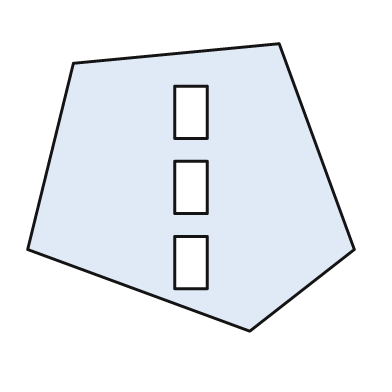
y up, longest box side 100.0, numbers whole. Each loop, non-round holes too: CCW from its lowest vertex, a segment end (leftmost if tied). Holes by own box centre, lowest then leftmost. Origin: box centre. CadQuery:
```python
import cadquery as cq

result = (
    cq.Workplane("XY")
    .moveTo(18.0, -44.0)
    .lineTo(50.0, -19.0)
    .lineTo(27.0, 44.0)
    .lineTo(-36.0, 38.0)
    .lineTo(-50.0, -19.0)
    .close()
    .moveTo(-5.0, -31.0)
    .lineTo(5.0, -31.0)
    .lineTo(5.0, -15.0)
    .lineTo(-5.0, -15.0)
    .close()
    .moveTo(-5.0, -8.0)
    .lineTo(5.0, -8.0)
    .lineTo(5.0, 8.0)
    .lineTo(-5.0, 8.0)
    .close()
    .moveTo(-5.0, 15.0)
    .lineTo(5.0, 15.0)
    .lineTo(5.0, 31.0)
    .lineTo(-5.0, 31.0)
    .close()
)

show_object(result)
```